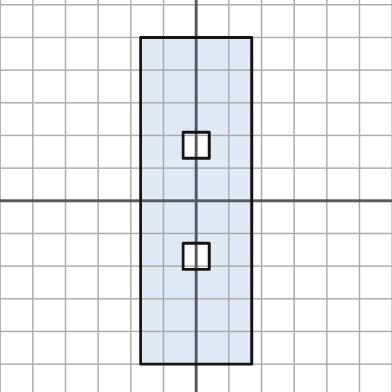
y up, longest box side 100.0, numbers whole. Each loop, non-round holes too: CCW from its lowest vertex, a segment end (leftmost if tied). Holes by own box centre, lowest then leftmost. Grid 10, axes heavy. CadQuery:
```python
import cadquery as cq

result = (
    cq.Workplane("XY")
    .moveTo(-17.0, -50.0)
    .lineTo(17.0, -50.0)
    .lineTo(17.0, 50.0)
    .lineTo(-17.0, 50.0)
    .close()
    .moveTo(-4.0, -21.0)
    .lineTo(4.0, -21.0)
    .lineTo(4.0, -13.0)
    .lineTo(-4.0, -13.0)
    .close()
    .moveTo(-4.0, 13.0)
    .lineTo(4.0, 13.0)
    .lineTo(4.0, 21.0)
    .lineTo(-4.0, 21.0)
    .close()
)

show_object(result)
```